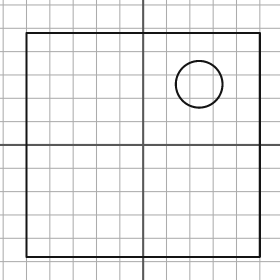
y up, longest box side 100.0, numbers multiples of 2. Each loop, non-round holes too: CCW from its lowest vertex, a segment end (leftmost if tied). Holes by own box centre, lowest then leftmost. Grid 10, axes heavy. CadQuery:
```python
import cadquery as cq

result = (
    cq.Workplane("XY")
    .moveTo(-50.0, -48.0)
    .lineTo(50.0, -48.0)
    .lineTo(50.0, 48.0)
    .lineTo(-50.0, 48.0)
    .close()
    .moveTo(24.0, 26.0)
    .circle(10.0)
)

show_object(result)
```